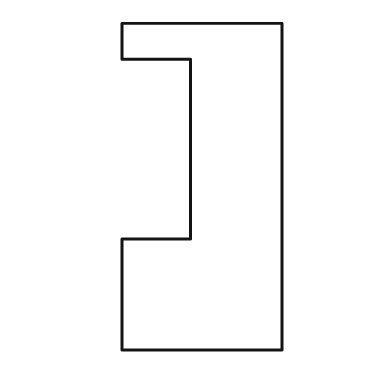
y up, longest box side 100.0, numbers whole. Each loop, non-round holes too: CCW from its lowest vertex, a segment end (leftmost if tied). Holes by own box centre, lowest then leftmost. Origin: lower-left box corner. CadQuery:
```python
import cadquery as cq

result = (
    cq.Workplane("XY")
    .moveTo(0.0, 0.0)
    .lineTo(49.0, 0.0)
    .lineTo(49.0, 100.0)
    .lineTo(0.0, 100.0)
    .lineTo(0.0, 89.0)
    .lineTo(21.0, 89.0)
    .lineTo(21.0, 34.0)
    .lineTo(0.0, 34.0)
    .close()
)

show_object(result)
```